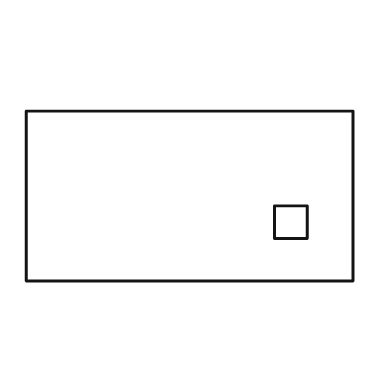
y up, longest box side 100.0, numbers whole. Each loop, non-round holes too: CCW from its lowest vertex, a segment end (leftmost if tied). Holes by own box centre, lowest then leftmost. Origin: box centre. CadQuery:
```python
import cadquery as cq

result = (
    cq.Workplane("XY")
    .moveTo(-50.0, -26.0)
    .lineTo(50.0, -26.0)
    .lineTo(50.0, 26.0)
    .lineTo(-50.0, 26.0)
    .close()
    .moveTo(26.0, -13.0)
    .lineTo(36.0, -13.0)
    .lineTo(36.0, -3.0)
    .lineTo(26.0, -3.0)
    .close()
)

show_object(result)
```